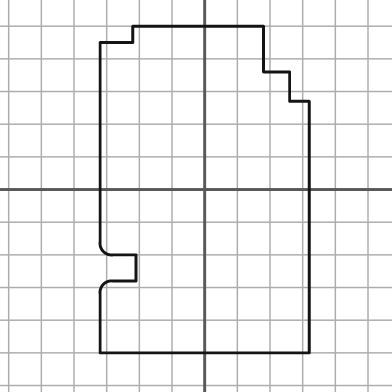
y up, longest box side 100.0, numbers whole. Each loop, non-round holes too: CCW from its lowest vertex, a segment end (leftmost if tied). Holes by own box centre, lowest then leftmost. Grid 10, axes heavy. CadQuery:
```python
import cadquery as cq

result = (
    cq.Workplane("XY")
    .moveTo(-32.0, -50.0)
    .lineTo(32.0, -50.0)
    .lineTo(32.0, 27.0)
    .lineTo(26.0, 27.0)
    .lineTo(26.0, 36.0)
    .lineTo(18.0, 36.0)
    .lineTo(18.0, 50.0)
    .lineTo(-22.0, 50.0)
    .lineTo(-22.0, 45.0)
    .lineTo(-32.0, 45.0)
    .lineTo(-32.0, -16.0)
    .threePointArc((-31.0, -19.0), (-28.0, -20.0))
    .lineTo(-21.0, -20.0)
    .lineTo(-21.0, -28.0)
    .lineTo(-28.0, -28.0)
    .threePointArc((-31.0, -29.0), (-32.0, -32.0))
    .close()
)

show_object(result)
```